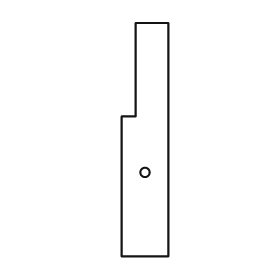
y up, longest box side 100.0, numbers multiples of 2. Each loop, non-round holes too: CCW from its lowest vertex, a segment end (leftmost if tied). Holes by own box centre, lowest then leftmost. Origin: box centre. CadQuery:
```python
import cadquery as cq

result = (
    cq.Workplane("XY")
    .moveTo(-10.0, -50.0)
    .lineTo(10.0, -50.0)
    .lineTo(10.0, 50.0)
    .lineTo(-4.0, 50.0)
    .lineTo(-4.0, 10.0)
    .lineTo(-10.0, 10.0)
    .close()
    .moveTo(0.0, -14.0)
    .circle(2.0)
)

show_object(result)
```